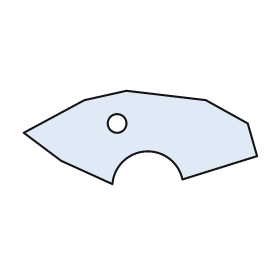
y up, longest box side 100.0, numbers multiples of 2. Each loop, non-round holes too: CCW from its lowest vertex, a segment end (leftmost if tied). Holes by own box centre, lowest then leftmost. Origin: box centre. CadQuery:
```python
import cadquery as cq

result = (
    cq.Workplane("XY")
    .moveTo(-12.0, -20.0)
    .threePointArc((2.0, -6.0), (18.0, -18.0))
    .lineTo(50.0, -8.0)
    .lineTo(46.0, 6.0)
    .lineTo(28.0, 16.0)
    .lineTo(-6.0, 20.0)
    .lineTo(-24.0, 16.0)
    .lineTo(-50.0, 2.0)
    .lineTo(-34.0, -10.0)
    .close()
    .moveTo(-10.0, 6.0)
    .circle(4.0)
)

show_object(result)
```